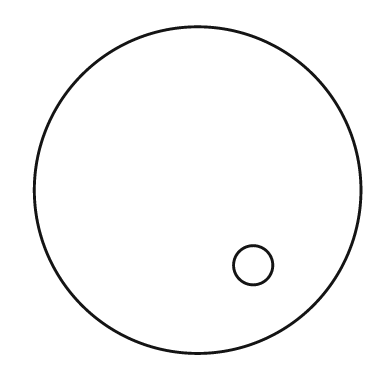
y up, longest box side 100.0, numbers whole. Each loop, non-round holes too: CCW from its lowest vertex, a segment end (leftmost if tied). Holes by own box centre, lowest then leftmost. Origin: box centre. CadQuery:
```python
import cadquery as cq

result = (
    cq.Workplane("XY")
    .moveTo(0.0, 0.0)
    .circle(50.0)
    .moveTo(17.0, -23.0)
    .circle(6.0)
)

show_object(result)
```